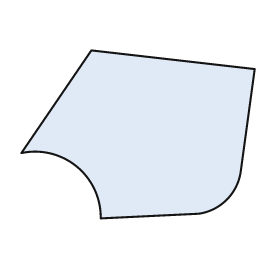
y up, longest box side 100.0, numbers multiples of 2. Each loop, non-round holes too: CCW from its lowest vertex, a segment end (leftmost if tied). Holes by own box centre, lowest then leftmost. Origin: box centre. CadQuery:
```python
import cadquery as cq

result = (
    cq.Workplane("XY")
    .moveTo(-16.0, -36.0)
    .lineTo(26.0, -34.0)
    .threePointArc((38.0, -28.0), (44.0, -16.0))
    .lineTo(50.0, 28.0)
    .lineTo(-20.0, 36.0)
    .lineTo(-50.0, -8.0)
    .threePointArc((-26.0, -14.0), (-16.0, -36.0))
    .close()
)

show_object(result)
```